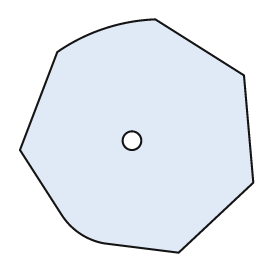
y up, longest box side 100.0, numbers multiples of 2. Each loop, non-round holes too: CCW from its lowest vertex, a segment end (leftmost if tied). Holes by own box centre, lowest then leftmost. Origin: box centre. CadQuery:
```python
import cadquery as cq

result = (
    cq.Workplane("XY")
    .moveTo(18.0, -50.0)
    .lineTo(50.0, -20.0)
    .lineTo(46.0, 26.0)
    .lineTo(8.0, 50.0)
    .threePointArc((-14.0, 46.0), (-34.0, 36.0))
    .lineTo(-50.0, -6.0)
    .lineTo(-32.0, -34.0)
    .threePointArc((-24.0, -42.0), (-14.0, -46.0))
    .close()
    .moveTo(-2.0, -2.0)
    .circle(4.0)
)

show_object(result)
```